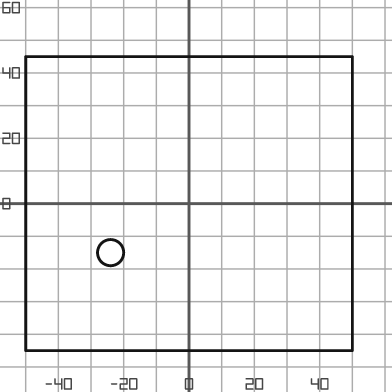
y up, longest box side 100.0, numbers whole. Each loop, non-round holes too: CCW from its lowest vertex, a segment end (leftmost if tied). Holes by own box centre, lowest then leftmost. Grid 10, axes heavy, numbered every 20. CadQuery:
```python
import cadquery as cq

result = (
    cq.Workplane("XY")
    .moveTo(-50.0, -45.0)
    .lineTo(50.0, -45.0)
    .lineTo(50.0, 45.0)
    .lineTo(-50.0, 45.0)
    .close()
    .moveTo(-24.0, -15.0)
    .circle(4.0)
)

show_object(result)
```